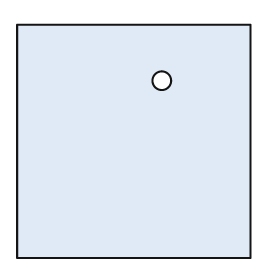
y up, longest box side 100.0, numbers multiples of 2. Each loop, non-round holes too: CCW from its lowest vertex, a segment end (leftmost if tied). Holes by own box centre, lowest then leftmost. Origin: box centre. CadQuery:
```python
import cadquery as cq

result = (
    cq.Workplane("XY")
    .moveTo(-50.0, -50.0)
    .lineTo(50.0, -50.0)
    .lineTo(50.0, 50.0)
    .lineTo(-50.0, 50.0)
    .close()
    .moveTo(12.0, 26.0)
    .circle(4.0)
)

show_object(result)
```